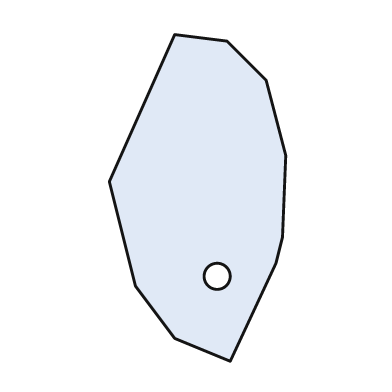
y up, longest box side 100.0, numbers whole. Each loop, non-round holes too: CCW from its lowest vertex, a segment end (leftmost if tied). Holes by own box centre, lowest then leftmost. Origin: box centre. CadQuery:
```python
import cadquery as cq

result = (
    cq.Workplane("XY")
    .moveTo(10.0, -50.0)
    .lineTo(24.0, -20.0)
    .lineTo(26.0, -12.0)
    .lineTo(27.0, 13.0)
    .lineTo(21.0, 36.0)
    .lineTo(9.0, 48.0)
    .lineTo(-7.0, 50.0)
    .lineTo(-27.0, 5.0)
    .lineTo(-19.0, -27.0)
    .lineTo(-7.0, -43.0)
    .close()
    .moveTo(6.0, -24.0)
    .circle(4.0)
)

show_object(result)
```